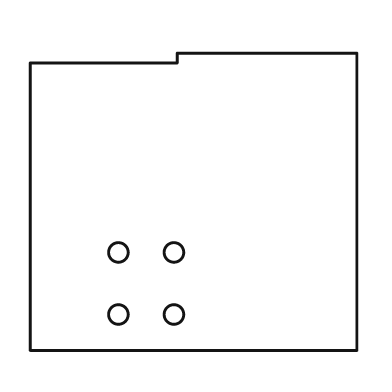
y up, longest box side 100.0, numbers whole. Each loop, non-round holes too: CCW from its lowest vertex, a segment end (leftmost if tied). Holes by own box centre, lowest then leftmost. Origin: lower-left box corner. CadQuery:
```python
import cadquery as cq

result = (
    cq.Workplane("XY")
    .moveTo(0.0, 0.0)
    .lineTo(100.0, 0.0)
    .lineTo(100.0, 91.0)
    .lineTo(45.0, 91.0)
    .lineTo(45.0, 88.0)
    .lineTo(0.0, 88.0)
    .close()
    .moveTo(27.0, 11.0)
    .circle(3.0)
    .moveTo(44.0, 11.0)
    .circle(3.0)
    .moveTo(27.0, 30.0)
    .circle(3.0)
    .moveTo(44.0, 30.0)
    .circle(3.0)
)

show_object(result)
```